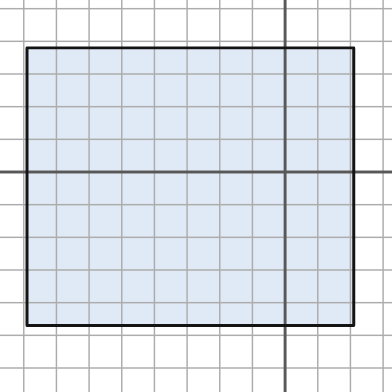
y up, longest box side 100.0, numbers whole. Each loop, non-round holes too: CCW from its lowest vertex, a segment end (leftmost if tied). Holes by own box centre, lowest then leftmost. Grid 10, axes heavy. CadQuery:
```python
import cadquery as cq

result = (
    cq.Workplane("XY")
    .moveTo(-79.0, -47.0)
    .lineTo(21.0, -47.0)
    .lineTo(21.0, 38.0)
    .lineTo(-79.0, 38.0)
    .close()
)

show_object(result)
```